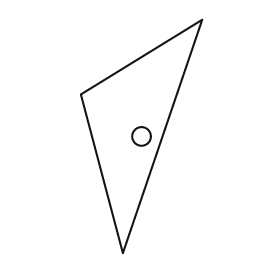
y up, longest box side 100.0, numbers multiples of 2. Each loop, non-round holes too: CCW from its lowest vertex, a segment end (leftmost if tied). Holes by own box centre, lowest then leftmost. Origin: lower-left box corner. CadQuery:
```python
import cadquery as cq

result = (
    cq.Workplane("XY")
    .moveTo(18.0, 0.0)
    .lineTo(52.0, 100.0)
    .lineTo(0.0, 68.0)
    .close()
    .moveTo(26.0, 50.0)
    .circle(4.0)
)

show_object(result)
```